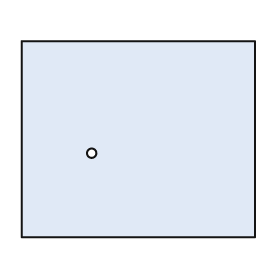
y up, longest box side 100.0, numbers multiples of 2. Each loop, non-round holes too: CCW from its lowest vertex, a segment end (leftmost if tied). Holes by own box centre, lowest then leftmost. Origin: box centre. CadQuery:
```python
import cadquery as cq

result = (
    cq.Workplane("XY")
    .moveTo(-50.0, -42.0)
    .lineTo(50.0, -42.0)
    .lineTo(50.0, 42.0)
    .lineTo(-50.0, 42.0)
    .close()
    .moveTo(-20.0, -6.0)
    .circle(2.0)
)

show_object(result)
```